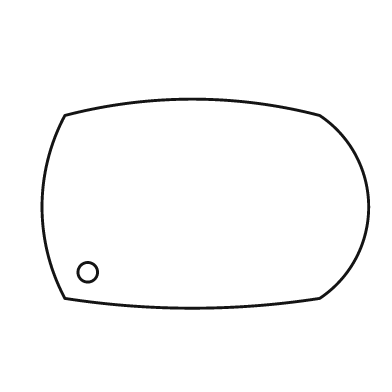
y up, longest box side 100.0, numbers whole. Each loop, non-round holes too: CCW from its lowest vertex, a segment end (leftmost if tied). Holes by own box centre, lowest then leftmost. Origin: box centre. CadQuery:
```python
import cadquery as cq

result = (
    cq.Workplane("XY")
    .moveTo(-43.0, -29.0)
    .threePointArc((-4.0, -32.0), (35.0, -29.0))
    .threePointArc((50.0, -1.0), (35.0, 27.0))
    .threePointArc((-4.0, 32.0), (-43.0, 27.0))
    .threePointArc((-50.0, -1.0), (-43.0, -29.0))
    .close()
    .moveTo(-36.0, -21.0)
    .circle(3.0)
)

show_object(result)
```